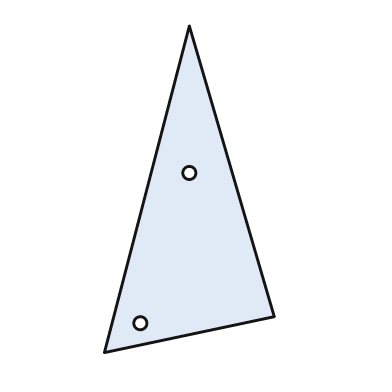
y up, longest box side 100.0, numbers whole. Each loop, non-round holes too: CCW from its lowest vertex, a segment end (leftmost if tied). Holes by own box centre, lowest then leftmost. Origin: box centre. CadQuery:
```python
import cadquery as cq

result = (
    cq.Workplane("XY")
    .moveTo(-26.0, -50.0)
    .lineTo(26.0, -39.0)
    .lineTo(0.0, 50.0)
    .close()
    .moveTo(-15.0, -41.0)
    .circle(2.0)
    .moveTo(0.0, 5.0)
    .circle(2.0)
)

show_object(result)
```